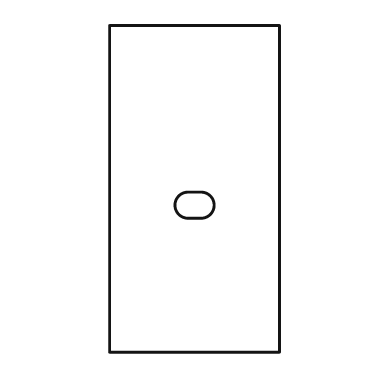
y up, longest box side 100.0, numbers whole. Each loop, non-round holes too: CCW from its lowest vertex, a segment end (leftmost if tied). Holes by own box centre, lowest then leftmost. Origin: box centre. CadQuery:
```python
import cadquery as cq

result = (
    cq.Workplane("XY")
    .moveTo(-26.0, -50.0)
    .lineTo(26.0, -50.0)
    .lineTo(26.0, 50.0)
    .lineTo(-26.0, 50.0)
    .close()
    .moveTo(-2.0, -9.0)
    .lineTo(2.0, -9.0)
    .threePointArc((6.0, -5.0), (2.0, -1.0))
    .lineTo(-2.0, -1.0)
    .threePointArc((-6.0, -5.0), (-2.0, -9.0))
    .close()
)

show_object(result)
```